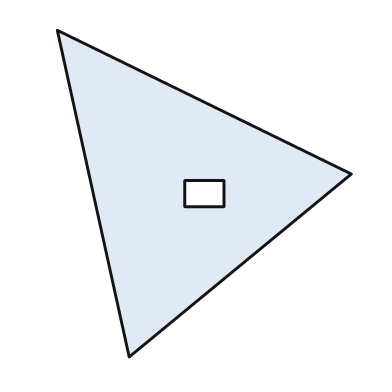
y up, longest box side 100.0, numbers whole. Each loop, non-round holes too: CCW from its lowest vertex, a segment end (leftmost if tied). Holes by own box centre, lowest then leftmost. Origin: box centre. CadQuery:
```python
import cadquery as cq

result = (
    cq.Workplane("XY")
    .moveTo(-23.0, -50.0)
    .lineTo(45.0, 6.0)
    .lineTo(-45.0, 50.0)
    .close()
    .moveTo(-6.0, -4.0)
    .lineTo(6.0, -4.0)
    .lineTo(6.0, 4.0)
    .lineTo(-6.0, 4.0)
    .close()
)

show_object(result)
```